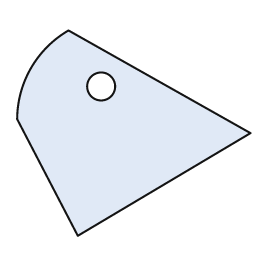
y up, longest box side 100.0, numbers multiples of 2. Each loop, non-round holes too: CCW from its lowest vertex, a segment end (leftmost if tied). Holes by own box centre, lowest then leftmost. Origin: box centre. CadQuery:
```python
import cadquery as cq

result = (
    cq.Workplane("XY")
    .moveTo(-24.0, -44.0)
    .lineTo(50.0, 0.0)
    .lineTo(-28.0, 44.0)
    .threePointArc((-44.0, 28.0), (-50.0, 6.0))
    .close()
    .moveTo(-14.0, 20.0)
    .circle(6.0)
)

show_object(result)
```